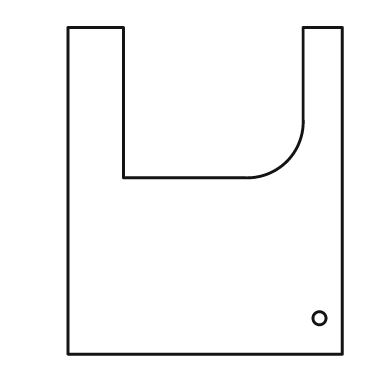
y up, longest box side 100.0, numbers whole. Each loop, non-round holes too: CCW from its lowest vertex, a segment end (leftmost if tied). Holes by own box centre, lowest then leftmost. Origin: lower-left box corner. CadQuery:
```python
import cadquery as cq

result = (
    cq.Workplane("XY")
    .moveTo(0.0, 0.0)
    .lineTo(84.0, 0.0)
    .lineTo(84.0, 100.0)
    .lineTo(72.0, 100.0)
    .lineTo(72.0, 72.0)
    .threePointArc((67.0, 59.0), (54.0, 54.0))
    .lineTo(17.0, 54.0)
    .lineTo(17.0, 100.0)
    .lineTo(0.0, 100.0)
    .close()
    .moveTo(77.0, 11.0)
    .circle(2.0)
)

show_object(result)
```